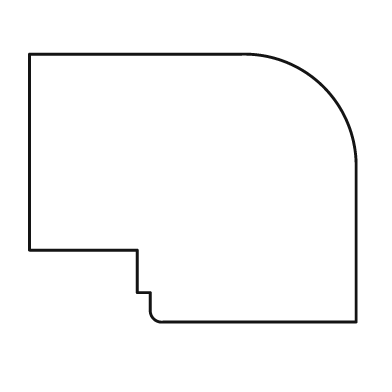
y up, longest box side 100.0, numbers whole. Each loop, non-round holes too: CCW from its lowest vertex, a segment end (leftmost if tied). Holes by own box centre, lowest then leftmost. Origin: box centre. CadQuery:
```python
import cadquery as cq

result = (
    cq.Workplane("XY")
    .moveTo(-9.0, -41.0)
    .lineTo(50.0, -41.0)
    .lineTo(50.0, 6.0)
    .threePointArc((40.0, 31.0), (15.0, 41.0))
    .lineTo(-50.0, 41.0)
    .lineTo(-50.0, -19.0)
    .lineTo(-17.0, -19.0)
    .lineTo(-17.0, -32.0)
    .lineTo(-13.0, -32.0)
    .lineTo(-13.0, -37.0)
    .threePointArc((-12.0, -40.0), (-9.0, -41.0))
    .close()
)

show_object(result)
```